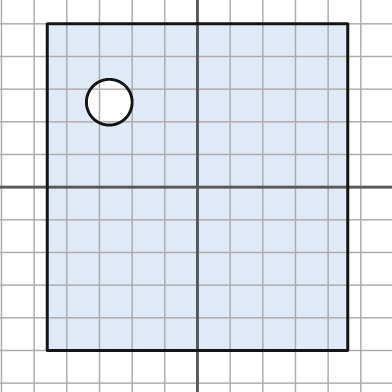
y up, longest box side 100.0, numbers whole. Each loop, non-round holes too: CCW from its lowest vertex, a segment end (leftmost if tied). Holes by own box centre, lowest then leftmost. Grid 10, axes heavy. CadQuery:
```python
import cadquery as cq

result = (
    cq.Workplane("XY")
    .moveTo(-46.0, -50.0)
    .lineTo(46.0, -50.0)
    .lineTo(46.0, 50.0)
    .lineTo(-46.0, 50.0)
    .close()
    .moveTo(-27.0, 26.0)
    .circle(7.0)
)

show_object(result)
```